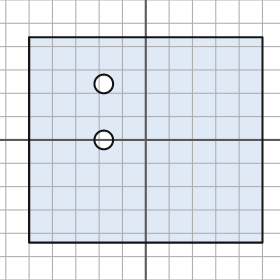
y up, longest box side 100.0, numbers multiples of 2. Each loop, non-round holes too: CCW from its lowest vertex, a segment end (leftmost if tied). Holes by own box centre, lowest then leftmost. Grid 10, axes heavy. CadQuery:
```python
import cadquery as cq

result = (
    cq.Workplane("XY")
    .moveTo(-50.0, -44.0)
    .lineTo(50.0, -44.0)
    .lineTo(50.0, 44.0)
    .lineTo(-50.0, 44.0)
    .close()
    .moveTo(-18.0, 0.0)
    .circle(4.0)
    .moveTo(-18.0, 24.0)
    .circle(4.0)
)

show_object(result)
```